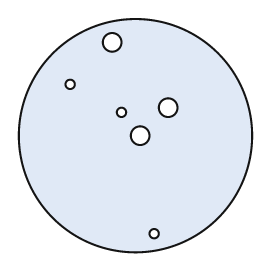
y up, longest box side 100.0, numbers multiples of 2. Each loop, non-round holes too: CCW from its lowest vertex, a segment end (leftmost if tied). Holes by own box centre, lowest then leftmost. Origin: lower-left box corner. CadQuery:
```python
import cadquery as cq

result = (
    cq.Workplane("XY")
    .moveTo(50.0, 50.0)
    .circle(50.0)
    .moveTo(58.0, 8.0)
    .circle(2.0)
    .moveTo(52.0, 50.0)
    .circle(4.0)
    .moveTo(44.0, 60.0)
    .circle(2.0)
    .moveTo(64.0, 62.0)
    .circle(4.0)
    .moveTo(22.0, 72.0)
    .circle(2.0)
    .moveTo(40.0, 90.0)
    .circle(4.0)
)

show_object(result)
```